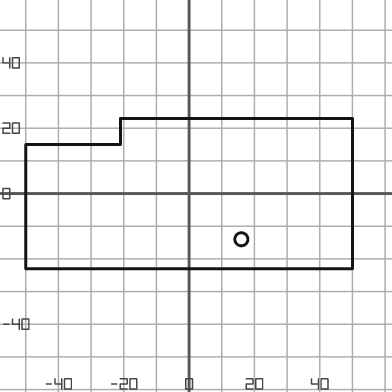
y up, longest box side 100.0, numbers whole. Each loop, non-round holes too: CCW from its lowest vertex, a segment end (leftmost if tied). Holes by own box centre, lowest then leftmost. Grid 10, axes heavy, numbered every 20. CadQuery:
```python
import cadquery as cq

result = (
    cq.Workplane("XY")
    .moveTo(-50.0, -23.0)
    .lineTo(50.0, -23.0)
    .lineTo(50.0, 23.0)
    .lineTo(-21.0, 23.0)
    .lineTo(-21.0, 15.0)
    .lineTo(-50.0, 15.0)
    .close()
    .moveTo(16.0, -14.0)
    .circle(2.0)
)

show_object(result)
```